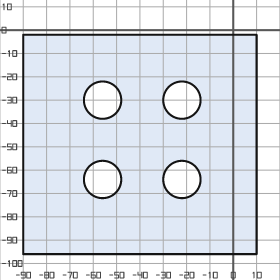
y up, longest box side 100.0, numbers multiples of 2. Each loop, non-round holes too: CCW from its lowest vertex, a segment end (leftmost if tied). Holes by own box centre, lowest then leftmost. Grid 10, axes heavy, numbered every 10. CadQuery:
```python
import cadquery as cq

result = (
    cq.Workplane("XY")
    .moveTo(-90.0, -96.0)
    .lineTo(10.0, -96.0)
    .lineTo(10.0, -2.0)
    .lineTo(-90.0, -2.0)
    .close()
    .moveTo(-56.0, -64.0)
    .circle(8.0)
    .moveTo(-22.0, -64.0)
    .circle(8.0)
    .moveTo(-56.0, -30.0)
    .circle(8.0)
    .moveTo(-22.0, -30.0)
    .circle(8.0)
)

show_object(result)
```